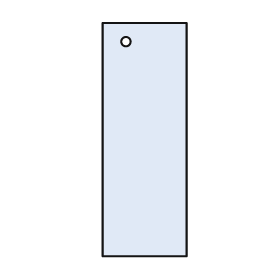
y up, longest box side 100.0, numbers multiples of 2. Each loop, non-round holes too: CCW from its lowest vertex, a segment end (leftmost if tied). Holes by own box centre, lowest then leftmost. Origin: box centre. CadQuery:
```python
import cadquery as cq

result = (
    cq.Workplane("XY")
    .moveTo(-18.0, -50.0)
    .lineTo(18.0, -50.0)
    .lineTo(18.0, 50.0)
    .lineTo(-18.0, 50.0)
    .close()
    .moveTo(-8.0, 42.0)
    .circle(2.0)
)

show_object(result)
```